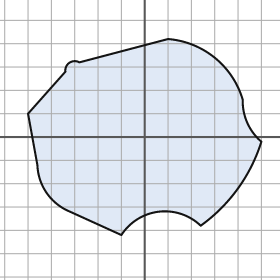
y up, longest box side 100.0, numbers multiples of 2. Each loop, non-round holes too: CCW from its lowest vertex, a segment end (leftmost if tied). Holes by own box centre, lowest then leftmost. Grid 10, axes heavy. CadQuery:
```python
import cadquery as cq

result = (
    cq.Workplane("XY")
    .moveTo(-10.0, -42.0)
    .threePointArc((6.0, -32.0), (24.0, -38.0))
    .threePointArc((40.0, -22.0), (50.0, -2.0))
    .threePointArc((44.0, 6.0), (42.0, 16.0))
    .threePointArc((30.0, 34.0), (10.0, 42.0))
    .lineTo(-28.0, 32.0)
    .threePointArc((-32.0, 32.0), (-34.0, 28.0))
    .lineTo(-50.0, 10.0)
    .lineTo(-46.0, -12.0)
    .threePointArc((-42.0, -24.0), (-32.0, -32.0))
    .close()
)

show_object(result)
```